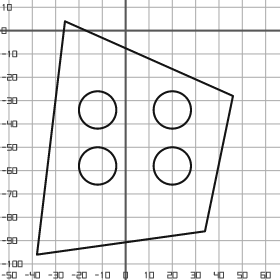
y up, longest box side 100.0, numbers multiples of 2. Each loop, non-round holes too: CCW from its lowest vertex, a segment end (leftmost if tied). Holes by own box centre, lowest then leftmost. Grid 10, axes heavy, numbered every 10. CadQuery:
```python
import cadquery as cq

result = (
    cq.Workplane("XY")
    .moveTo(-38.0, -96.0)
    .lineTo(34.0, -86.0)
    .lineTo(46.0, -28.0)
    .lineTo(-26.0, 4.0)
    .close()
    .moveTo(-12.0, -58.0)
    .circle(8.0)
    .moveTo(20.0, -58.0)
    .circle(8.0)
    .moveTo(-12.0, -34.0)
    .circle(8.0)
    .moveTo(20.0, -34.0)
    .circle(8.0)
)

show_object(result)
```